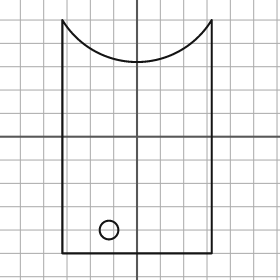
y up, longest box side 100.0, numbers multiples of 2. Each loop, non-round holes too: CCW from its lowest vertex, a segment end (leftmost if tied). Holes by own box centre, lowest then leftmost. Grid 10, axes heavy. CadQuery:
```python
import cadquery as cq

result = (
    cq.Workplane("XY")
    .moveTo(-32.0, -50.0)
    .lineTo(32.0, -50.0)
    .lineTo(32.0, 50.0)
    .threePointArc((0.0, 32.0), (-32.0, 50.0))
    .close()
    .moveTo(-12.0, -40.0)
    .circle(4.0)
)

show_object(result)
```